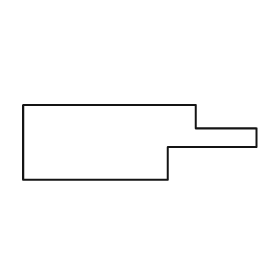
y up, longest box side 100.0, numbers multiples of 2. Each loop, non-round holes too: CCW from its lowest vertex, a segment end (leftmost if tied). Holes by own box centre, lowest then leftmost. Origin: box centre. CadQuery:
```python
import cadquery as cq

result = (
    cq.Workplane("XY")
    .moveTo(-50.0, -16.0)
    .lineTo(12.0, -16.0)
    .lineTo(12.0, -2.0)
    .lineTo(50.0, -2.0)
    .lineTo(50.0, 6.0)
    .lineTo(24.0, 6.0)
    .lineTo(24.0, 16.0)
    .lineTo(-50.0, 16.0)
    .close()
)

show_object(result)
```